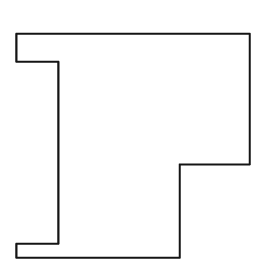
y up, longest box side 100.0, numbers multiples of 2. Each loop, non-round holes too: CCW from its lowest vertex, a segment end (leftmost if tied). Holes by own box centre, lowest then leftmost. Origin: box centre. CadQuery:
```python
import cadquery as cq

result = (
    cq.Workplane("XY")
    .moveTo(-50.0, -48.0)
    .lineTo(20.0, -48.0)
    .lineTo(20.0, -8.0)
    .lineTo(50.0, -8.0)
    .lineTo(50.0, 48.0)
    .lineTo(-50.0, 48.0)
    .lineTo(-50.0, 36.0)
    .lineTo(-32.0, 36.0)
    .lineTo(-32.0, -42.0)
    .lineTo(-50.0, -42.0)
    .close()
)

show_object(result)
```